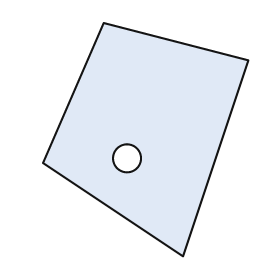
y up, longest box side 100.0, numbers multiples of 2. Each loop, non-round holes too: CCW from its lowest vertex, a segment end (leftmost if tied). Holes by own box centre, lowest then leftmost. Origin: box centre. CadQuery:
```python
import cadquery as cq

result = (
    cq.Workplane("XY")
    .moveTo(16.0, -50.0)
    .lineTo(44.0, 34.0)
    .lineTo(-18.0, 50.0)
    .lineTo(-44.0, -10.0)
    .close()
    .moveTo(-8.0, -8.0)
    .circle(6.0)
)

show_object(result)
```